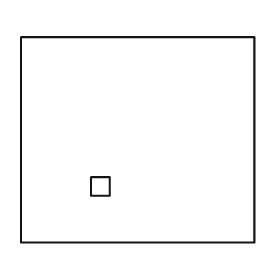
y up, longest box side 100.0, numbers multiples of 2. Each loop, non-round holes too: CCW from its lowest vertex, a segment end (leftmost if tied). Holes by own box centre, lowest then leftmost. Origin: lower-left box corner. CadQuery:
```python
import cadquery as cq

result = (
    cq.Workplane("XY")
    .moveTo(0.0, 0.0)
    .lineTo(100.0, 0.0)
    .lineTo(100.0, 88.0)
    .lineTo(0.0, 88.0)
    .close()
    .moveTo(30.0, 20.0)
    .lineTo(38.0, 20.0)
    .lineTo(38.0, 28.0)
    .lineTo(30.0, 28.0)
    .close()
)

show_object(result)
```